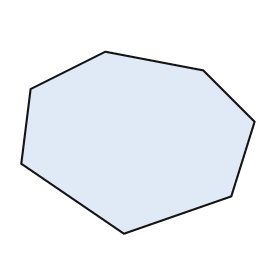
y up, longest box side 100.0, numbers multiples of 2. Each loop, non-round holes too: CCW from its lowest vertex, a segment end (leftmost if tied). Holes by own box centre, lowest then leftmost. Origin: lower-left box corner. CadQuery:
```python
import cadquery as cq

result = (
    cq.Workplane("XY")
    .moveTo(44.0, 0.0)
    .lineTo(90.0, 16.0)
    .lineTo(100.0, 48.0)
    .lineTo(78.0, 70.0)
    .lineTo(36.0, 78.0)
    .lineTo(4.0, 62.0)
    .lineTo(0.0, 30.0)
    .close()
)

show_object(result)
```